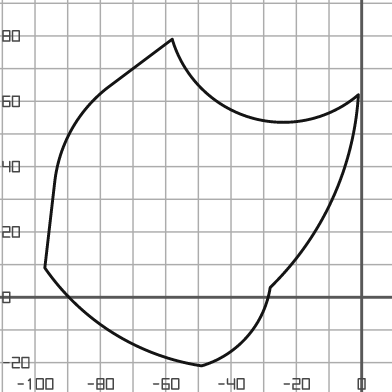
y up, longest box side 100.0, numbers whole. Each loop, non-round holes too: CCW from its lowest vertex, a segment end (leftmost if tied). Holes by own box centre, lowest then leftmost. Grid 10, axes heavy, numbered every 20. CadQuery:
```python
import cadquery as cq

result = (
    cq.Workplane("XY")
    .moveTo(-49.0, -21.0)
    .threePointArc((-35.0, -12.0), (-28.0, 3.0))
    .threePointArc((-9.0, 30.0), (-1.0, 62.0))
    .threePointArc((-34.0, 55.0), (-58.0, 79.0))
    .lineTo(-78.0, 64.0)
    .threePointArc((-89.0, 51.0), (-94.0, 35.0))
    .lineTo(-97.0, 9.0)
    .threePointArc((-76.0, -11.0), (-49.0, -21.0))
    .close()
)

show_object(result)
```